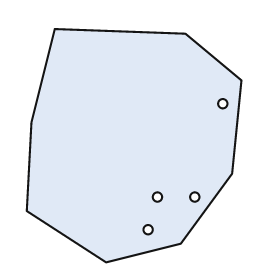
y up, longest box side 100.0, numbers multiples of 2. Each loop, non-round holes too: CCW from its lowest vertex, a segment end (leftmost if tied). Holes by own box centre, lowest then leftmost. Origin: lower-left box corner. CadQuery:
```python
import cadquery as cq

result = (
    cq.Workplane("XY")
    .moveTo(34.0, 0.0)
    .lineTo(66.0, 8.0)
    .lineTo(88.0, 38.0)
    .lineTo(92.0, 78.0)
    .lineTo(68.0, 98.0)
    .lineTo(12.0, 100.0)
    .lineTo(2.0, 60.0)
    .lineTo(0.0, 22.0)
    .close()
    .moveTo(52.0, 14.0)
    .circle(2.0)
    .moveTo(56.0, 28.0)
    .circle(2.0)
    .moveTo(72.0, 28.0)
    .circle(2.0)
    .moveTo(84.0, 68.0)
    .circle(2.0)
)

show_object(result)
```